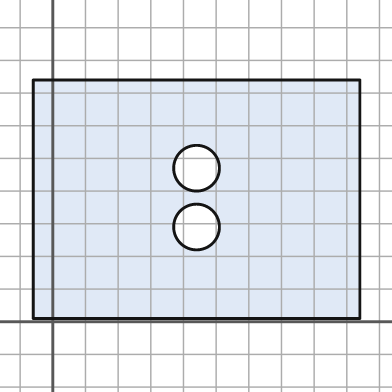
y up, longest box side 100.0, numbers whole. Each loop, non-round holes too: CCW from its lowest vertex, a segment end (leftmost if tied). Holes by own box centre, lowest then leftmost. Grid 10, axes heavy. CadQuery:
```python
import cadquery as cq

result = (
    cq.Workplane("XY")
    .moveTo(-6.0, 1.0)
    .lineTo(94.0, 1.0)
    .lineTo(94.0, 74.0)
    .lineTo(-6.0, 74.0)
    .close()
    .moveTo(44.0, 29.0)
    .circle(7.0)
    .moveTo(44.0, 47.0)
    .circle(7.0)
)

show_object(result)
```